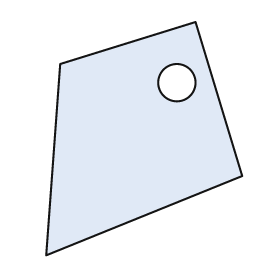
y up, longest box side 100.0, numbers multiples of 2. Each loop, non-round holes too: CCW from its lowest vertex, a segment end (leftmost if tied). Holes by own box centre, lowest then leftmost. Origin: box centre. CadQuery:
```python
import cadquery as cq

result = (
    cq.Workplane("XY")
    .moveTo(-42.0, -50.0)
    .lineTo(42.0, -16.0)
    .lineTo(22.0, 50.0)
    .lineTo(-36.0, 32.0)
    .close()
    .moveTo(14.0, 24.0)
    .circle(8.0)
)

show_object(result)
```